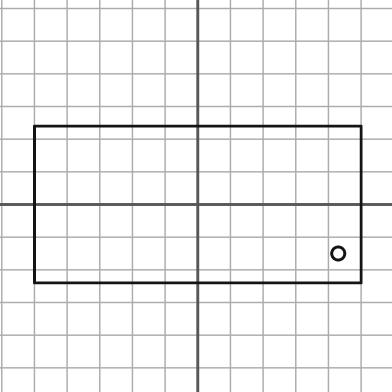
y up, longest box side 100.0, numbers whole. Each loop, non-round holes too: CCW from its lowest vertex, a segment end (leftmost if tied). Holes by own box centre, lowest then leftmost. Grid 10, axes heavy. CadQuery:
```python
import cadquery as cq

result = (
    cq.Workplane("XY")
    .moveTo(-50.0, -24.0)
    .lineTo(50.0, -24.0)
    .lineTo(50.0, 24.0)
    .lineTo(-50.0, 24.0)
    .close()
    .moveTo(43.0, -15.0)
    .circle(2.0)
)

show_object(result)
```